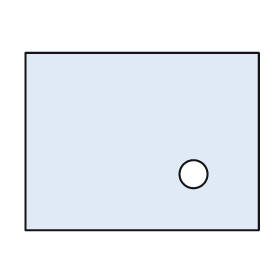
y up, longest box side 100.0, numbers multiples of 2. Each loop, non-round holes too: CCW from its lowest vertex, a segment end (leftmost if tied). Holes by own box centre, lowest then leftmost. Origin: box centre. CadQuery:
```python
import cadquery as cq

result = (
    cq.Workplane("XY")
    .moveTo(-50.0, -38.0)
    .lineTo(50.0, -38.0)
    .lineTo(50.0, 38.0)
    .lineTo(-50.0, 38.0)
    .close()
    .moveTo(22.0, -14.0)
    .circle(6.0)
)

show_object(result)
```